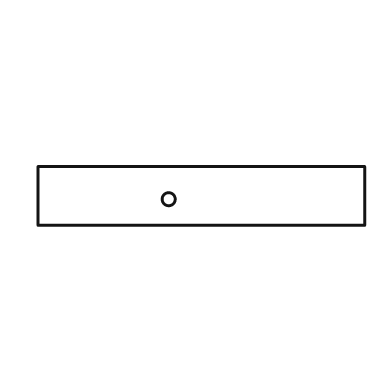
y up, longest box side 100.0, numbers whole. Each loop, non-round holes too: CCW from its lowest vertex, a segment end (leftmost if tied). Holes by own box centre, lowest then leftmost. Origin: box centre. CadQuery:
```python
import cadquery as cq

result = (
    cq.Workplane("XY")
    .moveTo(-50.0, -9.0)
    .lineTo(50.0, -9.0)
    .lineTo(50.0, 9.0)
    .lineTo(-50.0, 9.0)
    .close()
    .moveTo(-10.0, -1.0)
    .circle(2.0)
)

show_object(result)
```